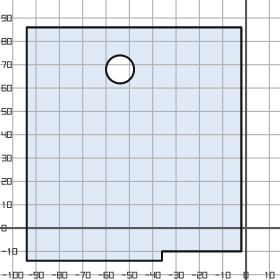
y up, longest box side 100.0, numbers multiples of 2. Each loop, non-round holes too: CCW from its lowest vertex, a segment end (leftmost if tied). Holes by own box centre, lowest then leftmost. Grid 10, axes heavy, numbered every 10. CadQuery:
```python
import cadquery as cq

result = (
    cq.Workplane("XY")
    .moveTo(-94.0, -14.0)
    .lineTo(-36.0, -14.0)
    .lineTo(-36.0, -10.0)
    .lineTo(-2.0, -10.0)
    .lineTo(-2.0, 86.0)
    .lineTo(-94.0, 86.0)
    .close()
    .moveTo(-54.0, 68.0)
    .circle(6.0)
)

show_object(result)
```